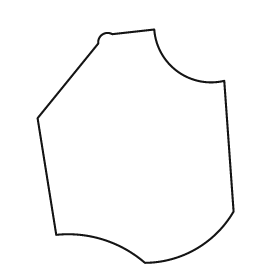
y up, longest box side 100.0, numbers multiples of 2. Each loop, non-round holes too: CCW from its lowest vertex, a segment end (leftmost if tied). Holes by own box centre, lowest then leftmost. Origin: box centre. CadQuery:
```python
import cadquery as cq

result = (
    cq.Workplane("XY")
    .moveTo(4.0, -50.0)
    .threePointArc((26.0, -44.0), (42.0, -28.0))
    .lineTo(38.0, 28.0)
    .threePointArc((18.0, 32.0), (8.0, 50.0))
    .lineTo(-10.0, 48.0)
    .threePointArc((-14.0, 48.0), (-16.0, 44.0))
    .lineTo(-42.0, 12.0)
    .lineTo(-34.0, -38.0)
    .threePointArc((-14.0, -40.0), (4.0, -50.0))
    .close()
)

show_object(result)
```